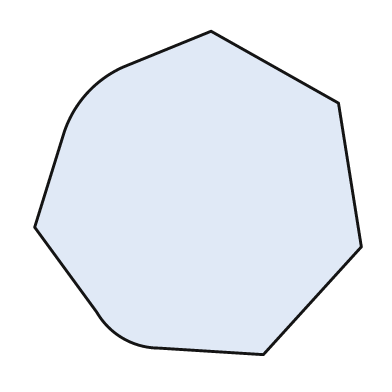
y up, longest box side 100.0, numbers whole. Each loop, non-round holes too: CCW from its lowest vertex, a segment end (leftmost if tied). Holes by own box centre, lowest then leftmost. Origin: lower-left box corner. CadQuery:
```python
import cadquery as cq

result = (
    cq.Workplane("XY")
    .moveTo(70.0, 0.0)
    .lineTo(100.0, 33.0)
    .lineTo(93.0, 77.0)
    .lineTo(54.0, 99.0)
    .lineTo(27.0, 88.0)
    .threePointArc((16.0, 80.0), (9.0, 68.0))
    .lineTo(0.0, 39.0)
    .lineTo(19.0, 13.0)
    .threePointArc((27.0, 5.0), (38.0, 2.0))
    .close()
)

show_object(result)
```